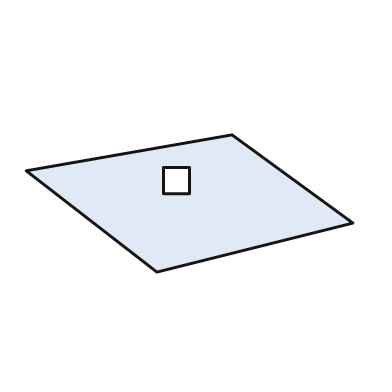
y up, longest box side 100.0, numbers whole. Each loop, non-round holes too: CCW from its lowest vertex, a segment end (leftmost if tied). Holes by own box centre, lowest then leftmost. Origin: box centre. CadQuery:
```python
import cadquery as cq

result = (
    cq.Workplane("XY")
    .moveTo(-10.0, -21.0)
    .lineTo(50.0, -6.0)
    .lineTo(13.0, 21.0)
    .lineTo(-50.0, 10.0)
    .close()
    .moveTo(-8.0, 3.0)
    .lineTo(0.0, 3.0)
    .lineTo(0.0, 11.0)
    .lineTo(-8.0, 11.0)
    .close()
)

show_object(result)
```